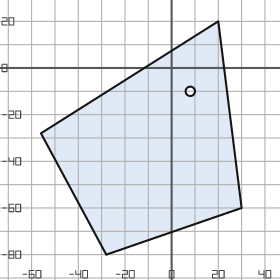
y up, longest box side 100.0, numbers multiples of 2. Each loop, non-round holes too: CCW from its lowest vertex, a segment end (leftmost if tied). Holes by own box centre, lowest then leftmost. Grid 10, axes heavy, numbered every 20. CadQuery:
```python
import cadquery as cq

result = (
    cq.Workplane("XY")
    .moveTo(-28.0, -80.0)
    .lineTo(30.0, -60.0)
    .lineTo(20.0, 20.0)
    .lineTo(-56.0, -28.0)
    .close()
    .moveTo(8.0, -10.0)
    .circle(2.0)
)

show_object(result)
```